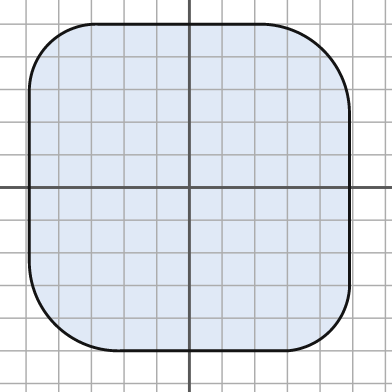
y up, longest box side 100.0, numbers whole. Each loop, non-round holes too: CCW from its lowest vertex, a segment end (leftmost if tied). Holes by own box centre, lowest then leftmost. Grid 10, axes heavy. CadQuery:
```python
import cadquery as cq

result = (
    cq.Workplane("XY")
    .moveTo(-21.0, -50.0)
    .lineTo(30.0, -50.0)
    .threePointArc((43.0, -44.0), (49.0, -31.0))
    .lineTo(49.0, 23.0)
    .threePointArc((41.0, 42.0), (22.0, 50.0))
    .lineTo(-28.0, 50.0)
    .threePointArc((-43.0, 44.0), (-49.0, 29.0))
    .lineTo(-49.0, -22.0)
    .threePointArc((-41.0, -42.0), (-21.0, -50.0))
    .close()
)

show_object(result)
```